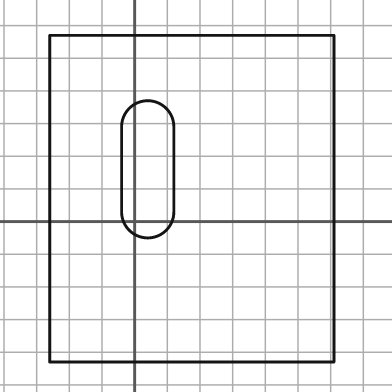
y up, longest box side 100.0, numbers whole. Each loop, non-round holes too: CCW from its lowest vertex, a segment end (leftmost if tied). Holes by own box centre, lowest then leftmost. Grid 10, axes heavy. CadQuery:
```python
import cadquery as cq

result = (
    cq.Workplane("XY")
    .moveTo(-26.0, -43.0)
    .lineTo(61.0, -43.0)
    .lineTo(61.0, 57.0)
    .lineTo(-26.0, 57.0)
    .close()
    .moveTo(-4.0, 3.0)
    .threePointArc((4.0, -5.0), (12.0, 3.0))
    .lineTo(12.0, 29.0)
    .threePointArc((4.0, 37.0), (-4.0, 29.0))
    .close()
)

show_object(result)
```